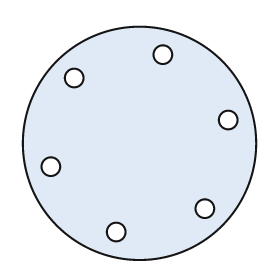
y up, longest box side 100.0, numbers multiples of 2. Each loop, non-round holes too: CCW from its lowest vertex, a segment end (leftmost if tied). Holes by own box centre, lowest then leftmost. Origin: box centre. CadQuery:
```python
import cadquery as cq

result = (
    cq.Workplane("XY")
    .moveTo(0.0, 0.0)
    .circle(50.0)
    .moveTo(-10.0, -38.0)
    .circle(4.0)
    .moveTo(28.0, -28.0)
    .circle(4.0)
    .moveTo(-38.0, -10.0)
    .circle(4.0)
    .moveTo(38.0, 10.0)
    .circle(4.0)
    .moveTo(-28.0, 28.0)
    .circle(4.0)
    .moveTo(10.0, 38.0)
    .circle(4.0)
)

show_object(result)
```